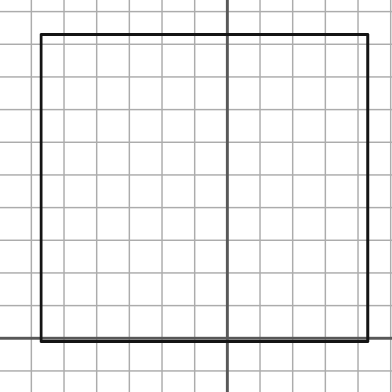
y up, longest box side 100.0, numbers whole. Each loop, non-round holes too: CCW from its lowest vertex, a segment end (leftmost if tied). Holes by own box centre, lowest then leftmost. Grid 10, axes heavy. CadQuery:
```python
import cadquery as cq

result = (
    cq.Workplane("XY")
    .moveTo(-57.0, -1.0)
    .lineTo(43.0, -1.0)
    .lineTo(43.0, 93.0)
    .lineTo(-57.0, 93.0)
    .close()
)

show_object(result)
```